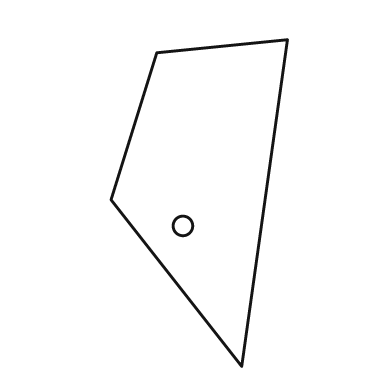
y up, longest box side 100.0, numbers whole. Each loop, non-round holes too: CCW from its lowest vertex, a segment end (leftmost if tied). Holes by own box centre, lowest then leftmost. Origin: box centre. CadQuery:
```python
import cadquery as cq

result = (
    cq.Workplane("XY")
    .moveTo(13.0, -50.0)
    .lineTo(27.0, 50.0)
    .lineTo(-13.0, 46.0)
    .lineTo(-27.0, 1.0)
    .close()
    .moveTo(-5.0, -7.0)
    .circle(3.0)
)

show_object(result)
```